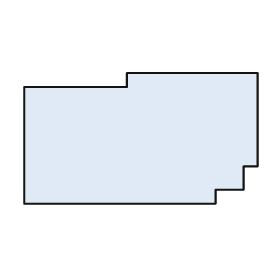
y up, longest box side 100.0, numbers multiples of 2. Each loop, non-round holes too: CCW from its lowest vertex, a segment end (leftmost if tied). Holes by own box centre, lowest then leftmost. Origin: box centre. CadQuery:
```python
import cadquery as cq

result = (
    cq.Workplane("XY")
    .moveTo(-50.0, -28.0)
    .lineTo(32.0, -28.0)
    .lineTo(32.0, -22.0)
    .lineTo(44.0, -22.0)
    .lineTo(44.0, -12.0)
    .lineTo(50.0, -12.0)
    .lineTo(50.0, 28.0)
    .lineTo(-6.0, 28.0)
    .lineTo(-6.0, 22.0)
    .lineTo(-50.0, 22.0)
    .close()
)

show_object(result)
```